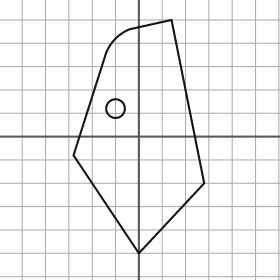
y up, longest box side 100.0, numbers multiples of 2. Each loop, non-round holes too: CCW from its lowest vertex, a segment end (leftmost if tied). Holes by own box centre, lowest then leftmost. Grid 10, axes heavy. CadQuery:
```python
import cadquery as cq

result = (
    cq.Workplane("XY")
    .moveTo(0.0, -50.0)
    .lineTo(28.0, -20.0)
    .lineTo(14.0, 50.0)
    .lineTo(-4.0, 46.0)
    .threePointArc((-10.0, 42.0), (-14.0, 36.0))
    .lineTo(-28.0, -8.0)
    .close()
    .moveTo(-10.0, 12.0)
    .circle(4.0)
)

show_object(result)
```